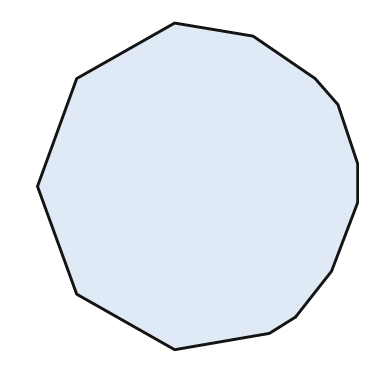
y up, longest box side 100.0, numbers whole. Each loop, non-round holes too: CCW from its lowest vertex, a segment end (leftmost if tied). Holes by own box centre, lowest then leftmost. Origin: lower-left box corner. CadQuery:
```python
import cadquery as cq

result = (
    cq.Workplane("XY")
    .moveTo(42.0, 0.0)
    .lineTo(71.0, 5.0)
    .lineTo(79.0, 10.0)
    .lineTo(90.0, 24.0)
    .lineTo(98.0, 45.0)
    .lineTo(98.0, 57.0)
    .lineTo(92.0, 75.0)
    .lineTo(85.0, 83.0)
    .lineTo(66.0, 96.0)
    .lineTo(42.0, 100.0)
    .lineTo(12.0, 83.0)
    .lineTo(0.0, 50.0)
    .lineTo(12.0, 17.0)
    .close()
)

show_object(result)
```